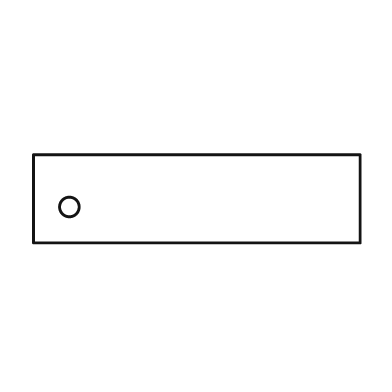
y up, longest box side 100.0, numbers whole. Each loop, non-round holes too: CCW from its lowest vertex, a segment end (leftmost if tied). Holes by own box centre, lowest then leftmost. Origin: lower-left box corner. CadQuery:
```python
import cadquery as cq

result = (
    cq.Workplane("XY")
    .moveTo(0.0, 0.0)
    .lineTo(100.0, 0.0)
    .lineTo(100.0, 27.0)
    .lineTo(0.0, 27.0)
    .close()
    .moveTo(11.0, 11.0)
    .circle(3.0)
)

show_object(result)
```